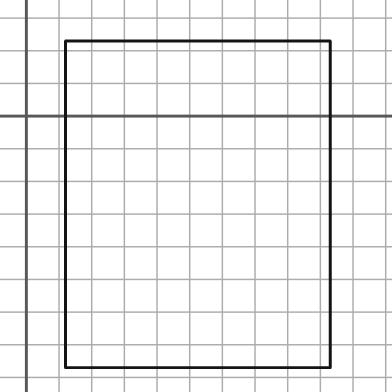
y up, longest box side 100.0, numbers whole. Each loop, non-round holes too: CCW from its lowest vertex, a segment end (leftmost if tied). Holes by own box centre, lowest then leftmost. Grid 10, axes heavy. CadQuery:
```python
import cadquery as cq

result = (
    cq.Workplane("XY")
    .moveTo(12.0, -77.0)
    .lineTo(93.0, -77.0)
    .lineTo(93.0, 23.0)
    .lineTo(12.0, 23.0)
    .close()
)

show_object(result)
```